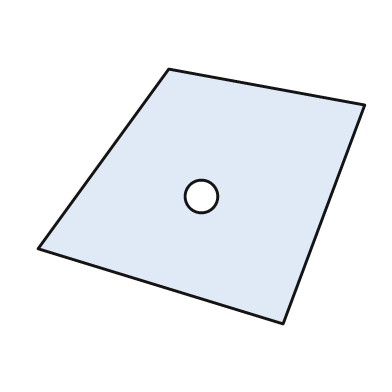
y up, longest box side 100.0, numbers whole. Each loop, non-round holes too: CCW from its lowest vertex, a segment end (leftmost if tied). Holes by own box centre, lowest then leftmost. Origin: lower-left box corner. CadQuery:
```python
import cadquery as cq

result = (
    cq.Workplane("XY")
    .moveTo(75.0, 0.0)
    .lineTo(100.0, 67.0)
    .lineTo(40.0, 78.0)
    .lineTo(0.0, 23.0)
    .close()
    .moveTo(50.0, 39.0)
    .circle(5.0)
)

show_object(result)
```